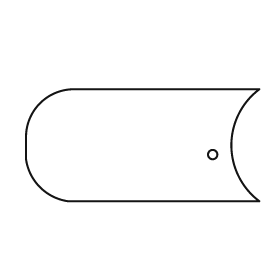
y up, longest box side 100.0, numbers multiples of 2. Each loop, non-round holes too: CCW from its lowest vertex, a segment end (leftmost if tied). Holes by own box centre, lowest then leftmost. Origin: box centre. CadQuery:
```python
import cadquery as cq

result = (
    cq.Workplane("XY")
    .moveTo(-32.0, -24.0)
    .lineTo(50.0, -24.0)
    .threePointArc((38.0, 0.0), (50.0, 24.0))
    .lineTo(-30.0, 24.0)
    .threePointArc((-44.0, 18.0), (-50.0, 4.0))
    .lineTo(-50.0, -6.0)
    .threePointArc((-44.0, -18.0), (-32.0, -24.0))
    .close()
    .moveTo(30.0, -4.0)
    .circle(2.0)
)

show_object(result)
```